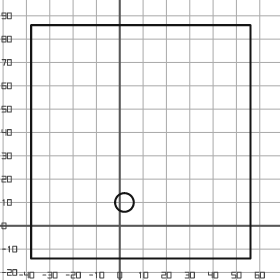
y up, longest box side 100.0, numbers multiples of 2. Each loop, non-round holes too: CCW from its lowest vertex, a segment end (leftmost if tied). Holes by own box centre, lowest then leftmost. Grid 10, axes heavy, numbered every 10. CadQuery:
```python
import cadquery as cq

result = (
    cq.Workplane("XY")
    .moveTo(-38.0, -14.0)
    .lineTo(56.0, -14.0)
    .lineTo(56.0, 86.0)
    .lineTo(-38.0, 86.0)
    .close()
    .moveTo(2.0, 10.0)
    .circle(4.0)
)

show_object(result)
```